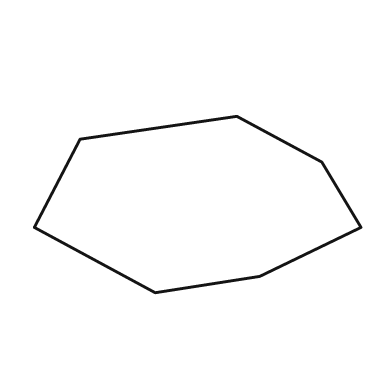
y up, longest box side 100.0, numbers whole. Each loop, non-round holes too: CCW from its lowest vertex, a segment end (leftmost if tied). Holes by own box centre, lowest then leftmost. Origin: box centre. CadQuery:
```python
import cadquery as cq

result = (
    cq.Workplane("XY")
    .moveTo(-13.0, -27.0)
    .lineTo(19.0, -22.0)
    .lineTo(50.0, -7.0)
    .lineTo(38.0, 13.0)
    .lineTo(12.0, 27.0)
    .lineTo(-36.0, 20.0)
    .lineTo(-50.0, -7.0)
    .close()
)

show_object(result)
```